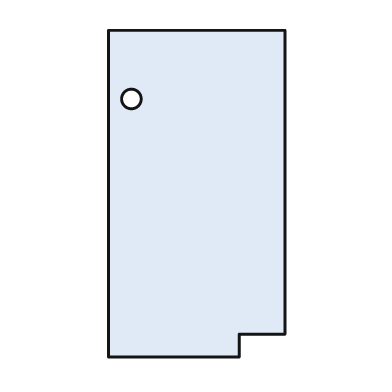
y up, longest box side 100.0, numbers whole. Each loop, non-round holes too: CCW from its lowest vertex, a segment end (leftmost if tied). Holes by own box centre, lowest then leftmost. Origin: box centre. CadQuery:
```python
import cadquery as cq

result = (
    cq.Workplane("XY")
    .moveTo(-27.0, -50.0)
    .lineTo(13.0, -50.0)
    .lineTo(13.0, -43.0)
    .lineTo(27.0, -43.0)
    .lineTo(27.0, 50.0)
    .lineTo(-27.0, 50.0)
    .close()
    .moveTo(-20.0, 29.0)
    .circle(3.0)
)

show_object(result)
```